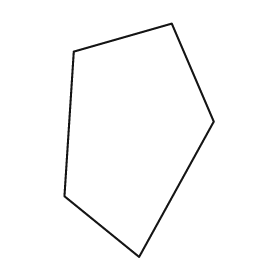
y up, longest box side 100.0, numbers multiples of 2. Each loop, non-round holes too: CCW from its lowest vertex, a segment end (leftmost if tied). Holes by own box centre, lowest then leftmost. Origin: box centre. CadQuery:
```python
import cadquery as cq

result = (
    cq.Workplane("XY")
    .moveTo(0.0, -50.0)
    .lineTo(32.0, 8.0)
    .lineTo(14.0, 50.0)
    .lineTo(-28.0, 38.0)
    .lineTo(-32.0, -24.0)
    .close()
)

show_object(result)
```